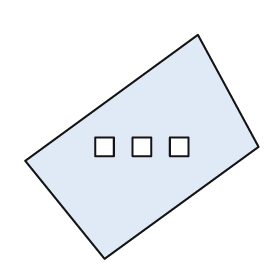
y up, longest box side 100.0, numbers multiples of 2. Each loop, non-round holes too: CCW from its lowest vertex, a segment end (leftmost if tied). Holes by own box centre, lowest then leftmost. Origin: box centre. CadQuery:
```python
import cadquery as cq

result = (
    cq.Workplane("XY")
    .moveTo(-16.0, -48.0)
    .lineTo(50.0, 0.0)
    .lineTo(24.0, 48.0)
    .lineTo(-50.0, -6.0)
    .close()
    .moveTo(-20.0, -4.0)
    .lineTo(-12.0, -4.0)
    .lineTo(-12.0, 4.0)
    .lineTo(-20.0, 4.0)
    .close()
    .moveTo(-4.0, -4.0)
    .lineTo(4.0, -4.0)
    .lineTo(4.0, 4.0)
    .lineTo(-4.0, 4.0)
    .close()
    .moveTo(12.0, -4.0)
    .lineTo(20.0, -4.0)
    .lineTo(20.0, 4.0)
    .lineTo(12.0, 4.0)
    .close()
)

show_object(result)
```